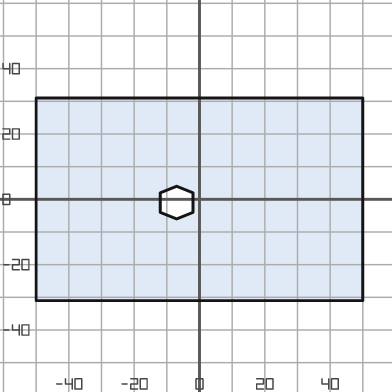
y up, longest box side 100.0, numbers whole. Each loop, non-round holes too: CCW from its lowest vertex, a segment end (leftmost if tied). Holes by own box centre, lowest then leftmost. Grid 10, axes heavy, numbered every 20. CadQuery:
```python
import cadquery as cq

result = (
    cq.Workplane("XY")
    .moveTo(-50.0, -31.0)
    .lineTo(50.0, -31.0)
    .lineTo(50.0, 31.0)
    .lineTo(-50.0, 31.0)
    .close()
    .moveTo(-7.0, -6.0)
    .lineTo(-2.0, -4.0)
    .lineTo(-2.0, 2.0)
    .lineTo(-7.0, 4.0)
    .lineTo(-12.0, 2.0)
    .lineTo(-12.0, -4.0)
    .close()
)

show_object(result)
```